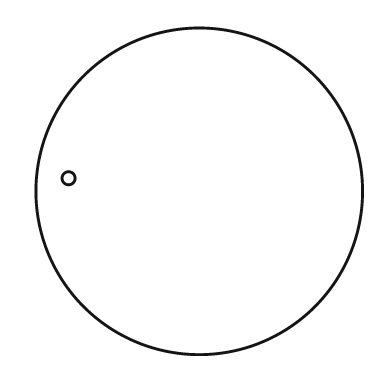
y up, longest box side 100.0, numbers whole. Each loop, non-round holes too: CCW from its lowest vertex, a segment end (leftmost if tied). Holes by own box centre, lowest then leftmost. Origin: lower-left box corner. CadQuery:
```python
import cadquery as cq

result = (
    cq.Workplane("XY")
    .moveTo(50.0, 50.0)
    .circle(50.0)
    .moveTo(10.0, 54.0)
    .circle(2.0)
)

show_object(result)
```